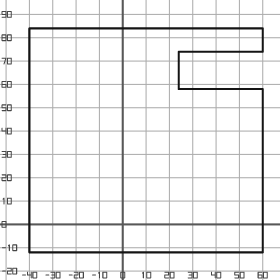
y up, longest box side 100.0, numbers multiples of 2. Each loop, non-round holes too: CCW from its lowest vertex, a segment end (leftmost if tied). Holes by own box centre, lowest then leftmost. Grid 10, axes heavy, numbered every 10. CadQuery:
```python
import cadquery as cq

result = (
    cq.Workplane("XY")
    .moveTo(-40.0, -12.0)
    .lineTo(60.0, -12.0)
    .lineTo(60.0, 58.0)
    .lineTo(24.0, 58.0)
    .lineTo(24.0, 74.0)
    .lineTo(60.0, 74.0)
    .lineTo(60.0, 84.0)
    .lineTo(-40.0, 84.0)
    .close()
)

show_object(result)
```